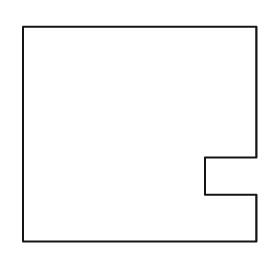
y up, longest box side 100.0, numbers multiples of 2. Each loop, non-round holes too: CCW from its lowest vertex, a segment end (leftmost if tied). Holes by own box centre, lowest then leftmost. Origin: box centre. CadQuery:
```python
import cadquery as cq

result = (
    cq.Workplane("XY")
    .moveTo(-50.0, -46.0)
    .lineTo(50.0, -46.0)
    .lineTo(50.0, -26.0)
    .lineTo(28.0, -26.0)
    .lineTo(28.0, -10.0)
    .lineTo(50.0, -10.0)
    .lineTo(50.0, 46.0)
    .lineTo(-50.0, 46.0)
    .close()
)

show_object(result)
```